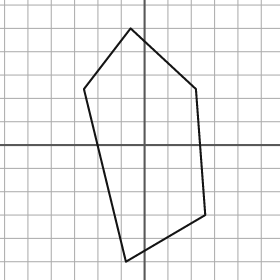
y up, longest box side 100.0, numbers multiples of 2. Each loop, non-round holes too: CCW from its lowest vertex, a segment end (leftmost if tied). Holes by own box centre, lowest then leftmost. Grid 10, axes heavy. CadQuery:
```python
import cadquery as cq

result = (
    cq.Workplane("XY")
    .moveTo(-8.0, -50.0)
    .lineTo(26.0, -30.0)
    .lineTo(22.0, 24.0)
    .lineTo(-6.0, 50.0)
    .lineTo(-26.0, 24.0)
    .close()
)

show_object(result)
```